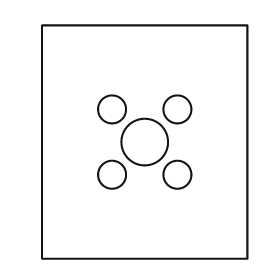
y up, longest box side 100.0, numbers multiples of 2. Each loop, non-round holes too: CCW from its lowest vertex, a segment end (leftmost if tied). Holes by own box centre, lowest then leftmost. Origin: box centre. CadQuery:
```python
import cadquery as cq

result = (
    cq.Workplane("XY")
    .moveTo(-44.0, -50.0)
    .lineTo(44.0, -50.0)
    .lineTo(44.0, 50.0)
    .lineTo(-44.0, 50.0)
    .close()
    .moveTo(-14.0, -14.0)
    .circle(6.0)
    .moveTo(14.0, -14.0)
    .circle(6.0)
    .moveTo(0.0, 0.0)
    .circle(10.0)
    .moveTo(-14.0, 14.0)
    .circle(6.0)
    .moveTo(14.0, 14.0)
    .circle(6.0)
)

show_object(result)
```